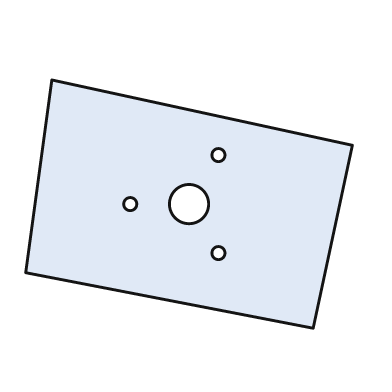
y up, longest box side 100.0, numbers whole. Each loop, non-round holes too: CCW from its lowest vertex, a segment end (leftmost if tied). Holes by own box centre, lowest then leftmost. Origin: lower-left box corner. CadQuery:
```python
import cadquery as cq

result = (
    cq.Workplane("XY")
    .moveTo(88.0, 0.0)
    .lineTo(100.0, 56.0)
    .lineTo(8.0, 76.0)
    .lineTo(0.0, 17.0)
    .close()
    .moveTo(59.0, 23.0)
    .circle(2.0)
    .moveTo(32.0, 38.0)
    .circle(2.0)
    .moveTo(50.0, 38.0)
    .circle(6.0)
    .moveTo(59.0, 53.0)
    .circle(2.0)
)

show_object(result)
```